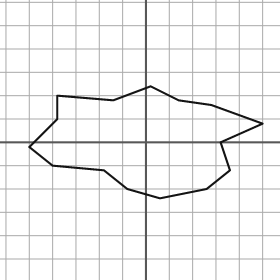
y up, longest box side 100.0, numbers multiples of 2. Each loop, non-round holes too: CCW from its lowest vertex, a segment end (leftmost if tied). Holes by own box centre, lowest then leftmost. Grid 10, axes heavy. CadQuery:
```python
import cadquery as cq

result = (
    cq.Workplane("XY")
    .moveTo(6.0, -24.0)
    .lineTo(26.0, -20.0)
    .lineTo(36.0, -12.0)
    .lineTo(32.0, 0.0)
    .lineTo(50.0, 8.0)
    .lineTo(28.0, 16.0)
    .lineTo(14.0, 18.0)
    .lineTo(2.0, 24.0)
    .lineTo(-14.0, 18.0)
    .lineTo(-38.0, 20.0)
    .lineTo(-38.0, 10.0)
    .lineTo(-50.0, -2.0)
    .lineTo(-40.0, -10.0)
    .lineTo(-18.0, -12.0)
    .lineTo(-8.0, -20.0)
    .close()
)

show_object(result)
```